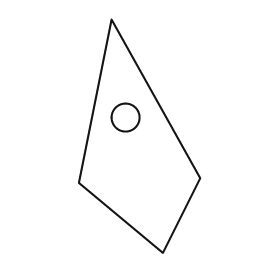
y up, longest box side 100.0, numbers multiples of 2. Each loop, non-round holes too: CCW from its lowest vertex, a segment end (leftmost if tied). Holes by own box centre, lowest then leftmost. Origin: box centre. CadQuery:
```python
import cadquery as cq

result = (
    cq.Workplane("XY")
    .moveTo(10.0, -50.0)
    .lineTo(26.0, -18.0)
    .lineTo(-12.0, 50.0)
    .lineTo(-26.0, -20.0)
    .close()
    .moveTo(-6.0, 8.0)
    .circle(6.0)
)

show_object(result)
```